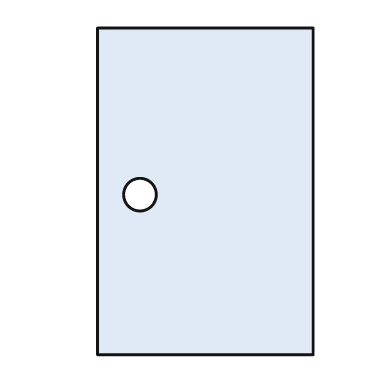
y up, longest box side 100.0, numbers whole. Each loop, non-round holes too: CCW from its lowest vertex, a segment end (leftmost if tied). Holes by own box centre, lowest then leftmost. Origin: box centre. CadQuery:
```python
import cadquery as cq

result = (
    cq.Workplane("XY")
    .moveTo(-33.0, -50.0)
    .lineTo(33.0, -50.0)
    .lineTo(33.0, 50.0)
    .lineTo(-33.0, 50.0)
    .close()
    .moveTo(-20.0, -1.0)
    .circle(5.0)
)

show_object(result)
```